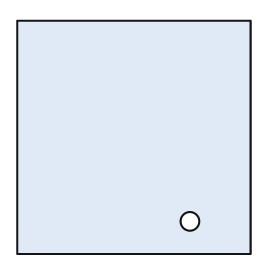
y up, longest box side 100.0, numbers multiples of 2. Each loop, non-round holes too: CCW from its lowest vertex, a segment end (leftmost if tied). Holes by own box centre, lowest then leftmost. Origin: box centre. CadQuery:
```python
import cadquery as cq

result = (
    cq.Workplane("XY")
    .moveTo(-50.0, -50.0)
    .lineTo(50.0, -50.0)
    .lineTo(50.0, 50.0)
    .lineTo(-50.0, 50.0)
    .close()
    .moveTo(24.0, -36.0)
    .circle(4.0)
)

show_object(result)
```